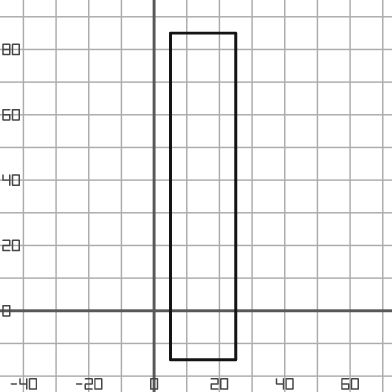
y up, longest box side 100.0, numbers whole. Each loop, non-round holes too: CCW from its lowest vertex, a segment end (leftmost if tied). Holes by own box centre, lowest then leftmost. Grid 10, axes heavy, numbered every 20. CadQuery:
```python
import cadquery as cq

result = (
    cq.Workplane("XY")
    .moveTo(5.0, -15.0)
    .lineTo(25.0, -15.0)
    .lineTo(25.0, 85.0)
    .lineTo(5.0, 85.0)
    .close()
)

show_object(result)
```